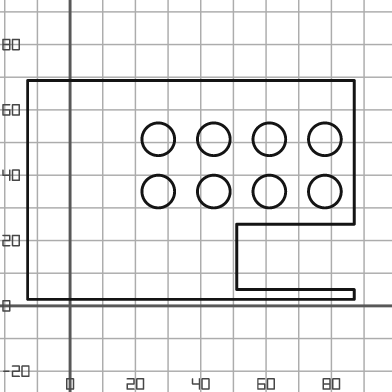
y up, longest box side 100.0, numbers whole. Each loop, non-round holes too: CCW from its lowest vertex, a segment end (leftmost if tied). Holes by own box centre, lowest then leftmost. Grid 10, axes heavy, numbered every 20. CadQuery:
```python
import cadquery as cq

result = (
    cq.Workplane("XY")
    .moveTo(-13.0, 2.0)
    .lineTo(87.0, 2.0)
    .lineTo(87.0, 5.0)
    .lineTo(51.0, 5.0)
    .lineTo(51.0, 25.0)
    .lineTo(87.0, 25.0)
    .lineTo(87.0, 69.0)
    .lineTo(-13.0, 69.0)
    .close()
    .moveTo(27.0, 35.0)
    .circle(5.0)
    .moveTo(44.0, 35.0)
    .circle(5.0)
    .moveTo(61.0, 35.0)
    .circle(5.0)
    .moveTo(78.0, 35.0)
    .circle(5.0)
    .moveTo(27.0, 51.0)
    .circle(5.0)
    .moveTo(44.0, 51.0)
    .circle(5.0)
    .moveTo(61.0, 51.0)
    .circle(5.0)
    .moveTo(78.0, 51.0)
    .circle(5.0)
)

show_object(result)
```